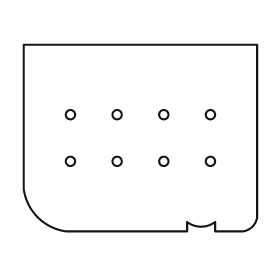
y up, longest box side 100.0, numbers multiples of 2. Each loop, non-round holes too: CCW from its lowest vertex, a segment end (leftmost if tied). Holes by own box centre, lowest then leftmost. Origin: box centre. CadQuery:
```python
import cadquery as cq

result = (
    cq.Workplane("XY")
    .moveTo(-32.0, -40.0)
    .lineTo(20.0, -40.0)
    .lineTo(20.0, -36.0)
    .threePointArc((26.0, -38.0), (32.0, -36.0))
    .lineTo(32.0, -40.0)
    .lineTo(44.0, -40.0)
    .threePointArc((48.0, -38.0), (50.0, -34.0))
    .lineTo(50.0, 40.0)
    .lineTo(-50.0, 40.0)
    .lineTo(-50.0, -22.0)
    .threePointArc((-44.0, -34.0), (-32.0, -40.0))
    .close()
    .moveTo(-30.0, -10.0)
    .circle(2.0)
    .moveTo(-10.0, -10.0)
    .circle(2.0)
    .moveTo(10.0, -10.0)
    .circle(2.0)
    .moveTo(30.0, -10.0)
    .circle(2.0)
    .moveTo(-30.0, 10.0)
    .circle(2.0)
    .moveTo(-10.0, 10.0)
    .circle(2.0)
    .moveTo(10.0, 10.0)
    .circle(2.0)
    .moveTo(30.0, 10.0)
    .circle(2.0)
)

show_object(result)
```